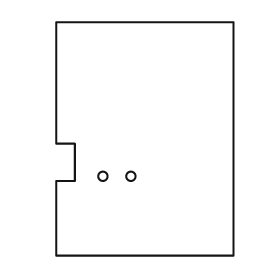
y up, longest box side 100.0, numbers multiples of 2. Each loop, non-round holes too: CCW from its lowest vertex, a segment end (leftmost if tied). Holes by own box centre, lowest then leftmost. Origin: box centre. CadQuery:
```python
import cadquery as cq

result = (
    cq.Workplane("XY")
    .moveTo(-38.0, -50.0)
    .lineTo(38.0, -50.0)
    .lineTo(38.0, 50.0)
    .lineTo(-38.0, 50.0)
    .lineTo(-38.0, -2.0)
    .lineTo(-30.0, -2.0)
    .lineTo(-30.0, -18.0)
    .lineTo(-38.0, -18.0)
    .close()
    .moveTo(-18.0, -16.0)
    .circle(2.0)
    .moveTo(-6.0, -16.0)
    .circle(2.0)
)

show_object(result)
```